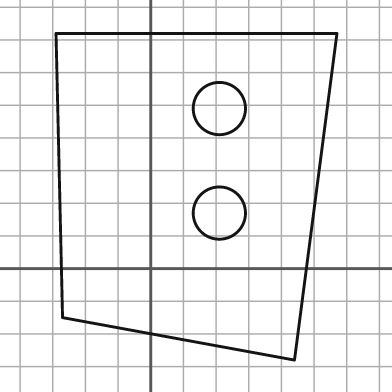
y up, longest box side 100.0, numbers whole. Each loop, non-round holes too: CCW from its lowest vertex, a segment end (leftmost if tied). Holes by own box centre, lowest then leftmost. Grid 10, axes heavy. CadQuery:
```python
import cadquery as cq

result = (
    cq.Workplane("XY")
    .moveTo(44.0, -28.0)
    .lineTo(57.0, 72.0)
    .lineTo(-29.0, 72.0)
    .lineTo(-27.0, -15.0)
    .close()
    .moveTo(21.0, 17.0)
    .circle(8.0)
    .moveTo(21.0, 49.0)
    .circle(8.0)
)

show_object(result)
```